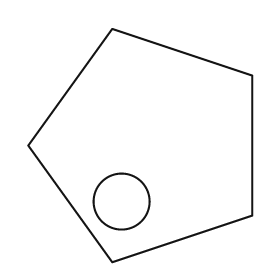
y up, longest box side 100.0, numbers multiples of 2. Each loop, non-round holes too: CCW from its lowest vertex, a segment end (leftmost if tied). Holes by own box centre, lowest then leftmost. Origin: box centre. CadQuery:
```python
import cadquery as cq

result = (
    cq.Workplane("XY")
    .moveTo(-12.0, -50.0)
    .lineTo(48.0, -30.0)
    .lineTo(48.0, 30.0)
    .lineTo(-12.0, 50.0)
    .lineTo(-48.0, 0.0)
    .close()
    .moveTo(-8.0, -24.0)
    .circle(12.0)
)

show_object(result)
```